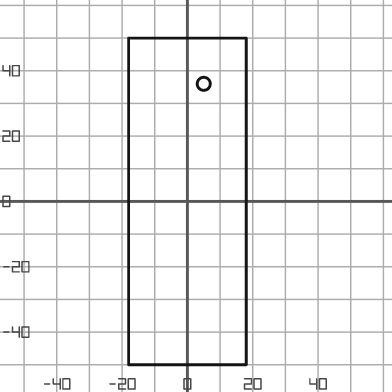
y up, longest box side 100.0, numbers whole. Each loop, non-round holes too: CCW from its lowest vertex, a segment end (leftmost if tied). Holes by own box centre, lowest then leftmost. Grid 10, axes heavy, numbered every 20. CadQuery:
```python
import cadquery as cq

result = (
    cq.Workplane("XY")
    .moveTo(-18.0, -50.0)
    .lineTo(18.0, -50.0)
    .lineTo(18.0, 50.0)
    .lineTo(-18.0, 50.0)
    .close()
    .moveTo(5.0, 36.0)
    .circle(2.0)
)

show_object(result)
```